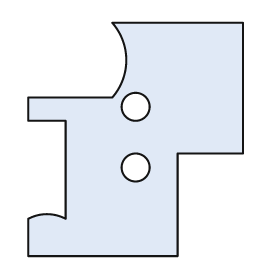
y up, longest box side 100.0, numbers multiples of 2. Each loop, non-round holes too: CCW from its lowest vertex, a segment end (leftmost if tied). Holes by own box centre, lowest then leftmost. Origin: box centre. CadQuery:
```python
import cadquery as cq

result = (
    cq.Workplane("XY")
    .moveTo(-46.0, -50.0)
    .lineTo(18.0, -50.0)
    .lineTo(18.0, -6.0)
    .lineTo(46.0, -6.0)
    .lineTo(46.0, 50.0)
    .lineTo(-10.0, 50.0)
    .threePointArc((-4.0, 34.0), (-10.0, 18.0))
    .lineTo(-46.0, 18.0)
    .lineTo(-46.0, 8.0)
    .lineTo(-30.0, 8.0)
    .lineTo(-30.0, -34.0)
    .threePointArc((-38.0, -32.0), (-46.0, -34.0))
    .close()
    .moveTo(0.0, -12.0)
    .circle(6.0)
    .moveTo(0.0, 14.0)
    .circle(6.0)
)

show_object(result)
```